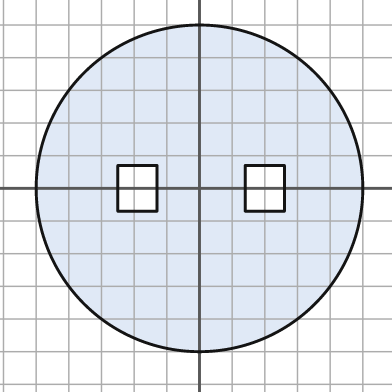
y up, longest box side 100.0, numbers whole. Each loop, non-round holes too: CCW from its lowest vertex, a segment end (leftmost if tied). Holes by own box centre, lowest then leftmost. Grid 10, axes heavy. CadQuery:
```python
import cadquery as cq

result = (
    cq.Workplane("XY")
    .moveTo(0.0, 0.0)
    .circle(50.0)
    .moveTo(-25.0, -7.0)
    .lineTo(-13.0, -7.0)
    .lineTo(-13.0, 7.0)
    .lineTo(-25.0, 7.0)
    .close()
    .moveTo(14.0, -7.0)
    .lineTo(26.0, -7.0)
    .lineTo(26.0, 7.0)
    .lineTo(14.0, 7.0)
    .close()
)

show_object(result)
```